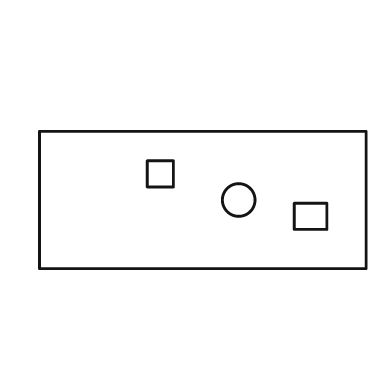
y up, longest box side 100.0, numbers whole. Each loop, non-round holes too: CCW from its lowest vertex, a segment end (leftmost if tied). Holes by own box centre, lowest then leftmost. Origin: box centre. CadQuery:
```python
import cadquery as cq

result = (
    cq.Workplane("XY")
    .moveTo(-50.0, -21.0)
    .lineTo(50.0, -21.0)
    .lineTo(50.0, 21.0)
    .lineTo(-50.0, 21.0)
    .close()
    .moveTo(28.0, -9.0)
    .lineTo(38.0, -9.0)
    .lineTo(38.0, -1.0)
    .lineTo(28.0, -1.0)
    .close()
    .moveTo(11.0, 0.0)
    .circle(5.0)
    .moveTo(-17.0, 4.0)
    .lineTo(-9.0, 4.0)
    .lineTo(-9.0, 12.0)
    .lineTo(-17.0, 12.0)
    .close()
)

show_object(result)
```